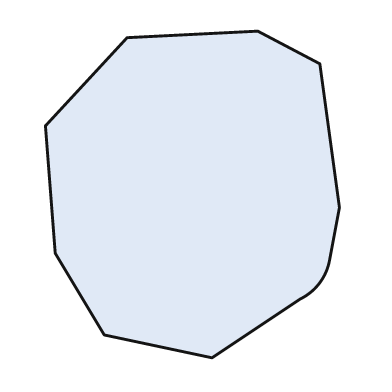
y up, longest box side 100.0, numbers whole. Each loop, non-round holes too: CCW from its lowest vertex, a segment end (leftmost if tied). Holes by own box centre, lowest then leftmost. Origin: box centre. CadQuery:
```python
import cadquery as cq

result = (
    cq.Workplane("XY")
    .moveTo(6.0, -50.0)
    .lineTo(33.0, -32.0)
    .threePointArc((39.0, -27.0), (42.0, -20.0))
    .lineTo(45.0, -4.0)
    .lineTo(39.0, 40.0)
    .lineTo(20.0, 50.0)
    .lineTo(-20.0, 48.0)
    .lineTo(-45.0, 21.0)
    .lineTo(-42.0, -18.0)
    .lineTo(-27.0, -43.0)
    .close()
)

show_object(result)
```